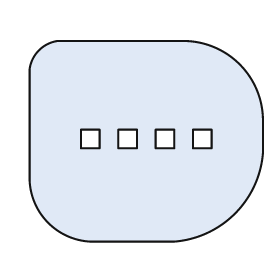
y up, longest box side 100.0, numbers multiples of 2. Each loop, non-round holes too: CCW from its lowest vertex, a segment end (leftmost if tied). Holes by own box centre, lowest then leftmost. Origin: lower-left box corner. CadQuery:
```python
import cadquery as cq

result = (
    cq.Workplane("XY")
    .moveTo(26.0, 0.0)
    .lineTo(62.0, 0.0)
    .threePointArc((88.0, 12.0), (100.0, 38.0))
    .lineTo(100.0, 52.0)
    .threePointArc((90.0, 76.0), (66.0, 86.0))
    .lineTo(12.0, 86.0)
    .threePointArc((4.0, 82.0), (0.0, 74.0))
    .lineTo(0.0, 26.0)
    .threePointArc((8.0, 8.0), (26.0, 0.0))
    .close()
    .moveTo(22.0, 40.0)
    .lineTo(30.0, 40.0)
    .lineTo(30.0, 48.0)
    .lineTo(22.0, 48.0)
    .close()
    .moveTo(38.0, 40.0)
    .lineTo(46.0, 40.0)
    .lineTo(46.0, 48.0)
    .lineTo(38.0, 48.0)
    .close()
    .moveTo(54.0, 40.0)
    .lineTo(62.0, 40.0)
    .lineTo(62.0, 48.0)
    .lineTo(54.0, 48.0)
    .close()
    .moveTo(70.0, 40.0)
    .lineTo(78.0, 40.0)
    .lineTo(78.0, 48.0)
    .lineTo(70.0, 48.0)
    .close()
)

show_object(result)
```